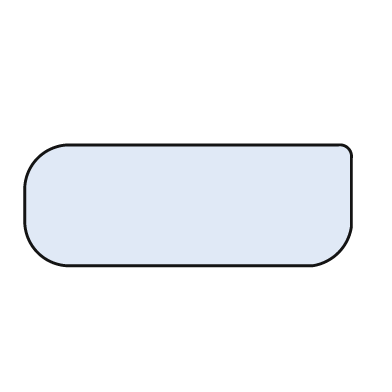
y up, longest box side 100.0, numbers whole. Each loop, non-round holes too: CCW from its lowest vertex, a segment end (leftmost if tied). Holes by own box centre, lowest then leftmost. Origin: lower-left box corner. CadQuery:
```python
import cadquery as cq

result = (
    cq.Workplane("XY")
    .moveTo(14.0, 0.0)
    .lineTo(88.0, 0.0)
    .threePointArc((96.0, 4.0), (100.0, 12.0))
    .lineTo(100.0, 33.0)
    .threePointArc((99.0, 36.0), (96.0, 37.0))
    .lineTo(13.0, 37.0)
    .threePointArc((4.0, 33.0), (0.0, 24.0))
    .lineTo(0.0, 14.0)
    .threePointArc((4.0, 4.0), (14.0, 0.0))
    .close()
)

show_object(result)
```